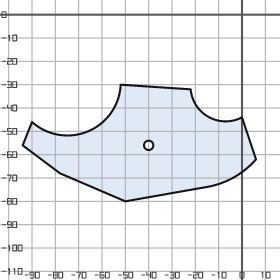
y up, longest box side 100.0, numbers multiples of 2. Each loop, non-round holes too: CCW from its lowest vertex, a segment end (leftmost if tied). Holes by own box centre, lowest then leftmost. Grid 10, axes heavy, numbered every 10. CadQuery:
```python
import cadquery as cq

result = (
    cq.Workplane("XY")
    .moveTo(-50.0, -80.0)
    .lineTo(-16.0, -74.0)
    .threePointArc((-4.0, -70.0), (6.0, -62.0))
    .lineTo(0.0, -44.0)
    .threePointArc((-14.0, -44.0), (-22.0, -32.0))
    .lineTo(-52.0, -30.0)
    .threePointArc((-66.0, -50.0), (-90.0, -46.0))
    .lineTo(-94.0, -56.0)
    .lineTo(-78.0, -68.0)
    .close()
    .moveTo(-40.0, -56.0)
    .circle(2.0)
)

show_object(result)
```